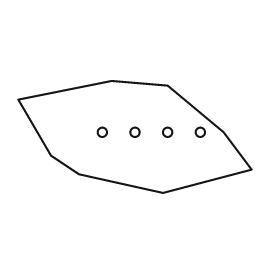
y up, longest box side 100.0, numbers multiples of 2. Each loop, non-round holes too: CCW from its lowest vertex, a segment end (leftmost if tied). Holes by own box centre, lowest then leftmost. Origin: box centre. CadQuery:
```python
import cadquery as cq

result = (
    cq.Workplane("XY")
    .moveTo(12.0, -24.0)
    .lineTo(50.0, -14.0)
    .lineTo(38.0, 2.0)
    .lineTo(14.0, 22.0)
    .lineTo(-10.0, 24.0)
    .lineTo(-50.0, 16.0)
    .lineTo(-36.0, -8.0)
    .lineTo(-24.0, -16.0)
    .close()
    .moveTo(-14.0, 2.0)
    .circle(2.0)
    .moveTo(0.0, 2.0)
    .circle(2.0)
    .moveTo(14.0, 2.0)
    .circle(2.0)
    .moveTo(28.0, 2.0)
    .circle(2.0)
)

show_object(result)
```